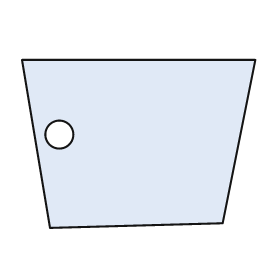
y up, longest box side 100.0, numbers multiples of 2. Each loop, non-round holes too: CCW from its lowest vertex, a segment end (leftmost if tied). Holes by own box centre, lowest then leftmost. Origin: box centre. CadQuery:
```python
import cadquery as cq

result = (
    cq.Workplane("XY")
    .moveTo(-38.0, -36.0)
    .lineTo(36.0, -34.0)
    .lineTo(50.0, 36.0)
    .lineTo(-50.0, 36.0)
    .close()
    .moveTo(-34.0, 4.0)
    .circle(6.0)
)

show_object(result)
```